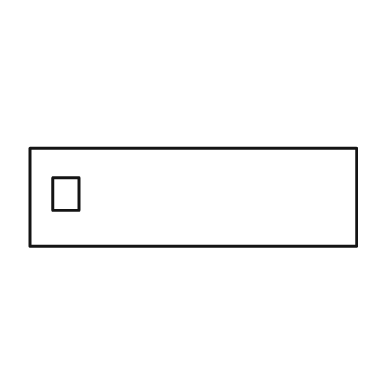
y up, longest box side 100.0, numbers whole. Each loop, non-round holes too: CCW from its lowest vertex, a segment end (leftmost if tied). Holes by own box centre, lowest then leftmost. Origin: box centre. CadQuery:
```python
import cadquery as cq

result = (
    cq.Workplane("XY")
    .moveTo(-50.0, -15.0)
    .lineTo(50.0, -15.0)
    .lineTo(50.0, 15.0)
    .lineTo(-50.0, 15.0)
    .close()
    .moveTo(-43.0, -4.0)
    .lineTo(-35.0, -4.0)
    .lineTo(-35.0, 6.0)
    .lineTo(-43.0, 6.0)
    .close()
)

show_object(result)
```